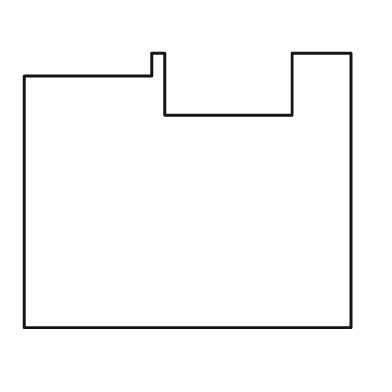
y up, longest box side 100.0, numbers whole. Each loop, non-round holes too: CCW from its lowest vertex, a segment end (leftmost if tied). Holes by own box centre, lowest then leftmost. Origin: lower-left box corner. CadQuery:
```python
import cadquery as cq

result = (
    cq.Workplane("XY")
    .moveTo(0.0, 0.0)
    .lineTo(100.0, 0.0)
    .lineTo(100.0, 84.0)
    .lineTo(82.0, 84.0)
    .lineTo(82.0, 65.0)
    .lineTo(43.0, 65.0)
    .lineTo(43.0, 84.0)
    .lineTo(39.0, 84.0)
    .lineTo(39.0, 77.0)
    .lineTo(0.0, 77.0)
    .close()
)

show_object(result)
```